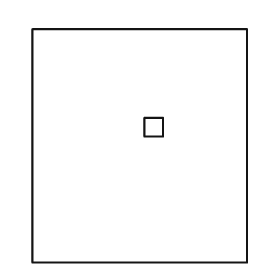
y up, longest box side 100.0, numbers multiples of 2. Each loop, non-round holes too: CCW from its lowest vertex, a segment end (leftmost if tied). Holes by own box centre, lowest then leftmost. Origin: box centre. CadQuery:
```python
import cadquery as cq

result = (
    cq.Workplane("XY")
    .moveTo(-46.0, -50.0)
    .lineTo(46.0, -50.0)
    .lineTo(46.0, 50.0)
    .lineTo(-46.0, 50.0)
    .close()
    .moveTo(2.0, 4.0)
    .lineTo(10.0, 4.0)
    .lineTo(10.0, 12.0)
    .lineTo(2.0, 12.0)
    .close()
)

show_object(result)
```